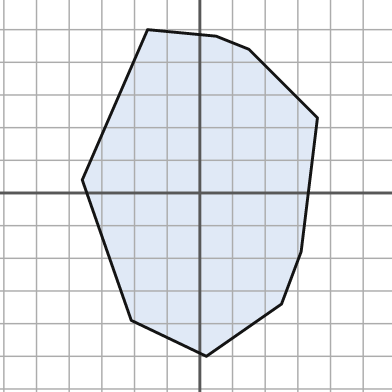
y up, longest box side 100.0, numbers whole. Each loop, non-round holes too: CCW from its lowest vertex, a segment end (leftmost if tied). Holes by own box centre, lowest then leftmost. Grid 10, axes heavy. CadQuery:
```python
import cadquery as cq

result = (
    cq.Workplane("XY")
    .moveTo(2.0, -50.0)
    .lineTo(25.0, -34.0)
    .lineTo(31.0, -18.0)
    .lineTo(36.0, 23.0)
    .lineTo(15.0, 44.0)
    .lineTo(5.0, 48.0)
    .lineTo(-16.0, 50.0)
    .lineTo(-36.0, 4.0)
    .lineTo(-21.0, -39.0)
    .close()
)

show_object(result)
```